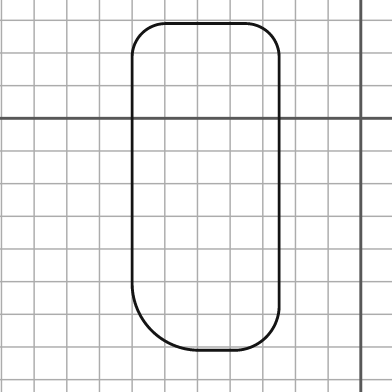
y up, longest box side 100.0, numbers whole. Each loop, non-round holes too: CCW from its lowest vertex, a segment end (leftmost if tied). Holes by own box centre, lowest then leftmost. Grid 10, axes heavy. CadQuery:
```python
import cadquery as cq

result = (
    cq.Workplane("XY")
    .moveTo(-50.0, -71.0)
    .lineTo(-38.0, -71.0)
    .threePointArc((-29.0, -67.0), (-25.0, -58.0))
    .lineTo(-25.0, 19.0)
    .threePointArc((-28.0, 26.0), (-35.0, 29.0))
    .lineTo(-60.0, 29.0)
    .threePointArc((-67.0, 26.0), (-70.0, 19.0))
    .lineTo(-70.0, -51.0)
    .threePointArc((-64.0, -65.0), (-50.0, -71.0))
    .close()
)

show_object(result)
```